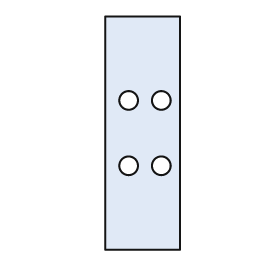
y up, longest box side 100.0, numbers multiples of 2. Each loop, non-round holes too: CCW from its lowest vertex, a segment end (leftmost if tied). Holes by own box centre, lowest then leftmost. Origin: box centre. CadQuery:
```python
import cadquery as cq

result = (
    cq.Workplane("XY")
    .moveTo(-16.0, -50.0)
    .lineTo(16.0, -50.0)
    .lineTo(16.0, 50.0)
    .lineTo(-16.0, 50.0)
    .close()
    .moveTo(-6.0, -14.0)
    .circle(4.0)
    .moveTo(8.0, -14.0)
    .circle(4.0)
    .moveTo(-6.0, 14.0)
    .circle(4.0)
    .moveTo(8.0, 14.0)
    .circle(4.0)
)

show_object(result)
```